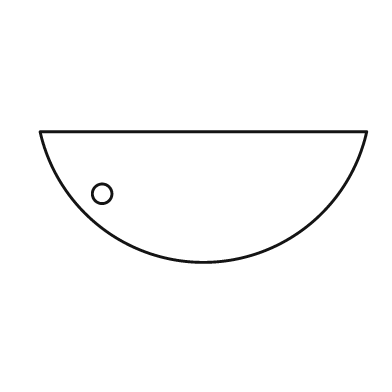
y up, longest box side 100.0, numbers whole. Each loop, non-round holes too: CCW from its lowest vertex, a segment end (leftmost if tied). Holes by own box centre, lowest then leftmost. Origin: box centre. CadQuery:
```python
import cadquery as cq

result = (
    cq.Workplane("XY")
    .moveTo(-50.0, 20.0)
    .threePointArc((0.0, -20.0), (50.0, 20.0))
    .close()
    .moveTo(-31.0, 1.0)
    .circle(3.0)
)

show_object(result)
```